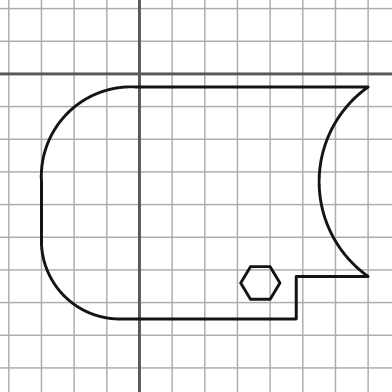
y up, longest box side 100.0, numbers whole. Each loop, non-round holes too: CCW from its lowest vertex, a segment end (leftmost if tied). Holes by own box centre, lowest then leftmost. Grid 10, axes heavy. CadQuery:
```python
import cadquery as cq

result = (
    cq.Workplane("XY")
    .moveTo(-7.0, -75.0)
    .lineTo(48.0, -75.0)
    .lineTo(48.0, -62.0)
    .lineTo(70.0, -62.0)
    .threePointArc((55.0, -33.0), (70.0, -4.0))
    .lineTo(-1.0, -4.0)
    .threePointArc((-22.0, -12.0), (-30.0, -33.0))
    .lineTo(-30.0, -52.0)
    .threePointArc((-23.0, -68.0), (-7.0, -75.0))
    .close()
    .moveTo(34.0, -69.0)
    .lineTo(40.0, -69.0)
    .lineTo(43.0, -64.0)
    .lineTo(40.0, -59.0)
    .lineTo(34.0, -59.0)
    .lineTo(31.0, -64.0)
    .close()
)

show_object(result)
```